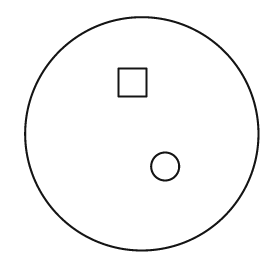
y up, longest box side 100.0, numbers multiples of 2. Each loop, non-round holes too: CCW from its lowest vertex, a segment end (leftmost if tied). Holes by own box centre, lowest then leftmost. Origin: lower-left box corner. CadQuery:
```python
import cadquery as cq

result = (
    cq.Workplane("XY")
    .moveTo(50.0, 50.0)
    .circle(50.0)
    .moveTo(60.0, 36.0)
    .circle(6.0)
    .moveTo(40.0, 66.0)
    .lineTo(52.0, 66.0)
    .lineTo(52.0, 78.0)
    .lineTo(40.0, 78.0)
    .close()
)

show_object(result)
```